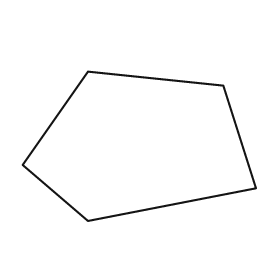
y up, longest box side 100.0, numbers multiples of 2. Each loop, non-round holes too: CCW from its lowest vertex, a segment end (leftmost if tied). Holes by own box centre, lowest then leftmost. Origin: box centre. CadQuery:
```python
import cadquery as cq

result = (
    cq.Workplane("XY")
    .moveTo(-22.0, -32.0)
    .lineTo(50.0, -18.0)
    .lineTo(36.0, 26.0)
    .lineTo(-22.0, 32.0)
    .lineTo(-50.0, -8.0)
    .close()
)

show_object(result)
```